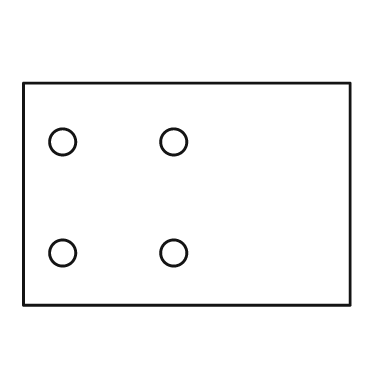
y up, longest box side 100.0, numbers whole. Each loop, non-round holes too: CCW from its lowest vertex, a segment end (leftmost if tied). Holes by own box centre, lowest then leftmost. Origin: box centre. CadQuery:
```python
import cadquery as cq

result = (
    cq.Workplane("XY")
    .moveTo(-50.0, -34.0)
    .lineTo(50.0, -34.0)
    .lineTo(50.0, 34.0)
    .lineTo(-50.0, 34.0)
    .close()
    .moveTo(-38.0, -18.0)
    .circle(4.0)
    .moveTo(-4.0, -18.0)
    .circle(4.0)
    .moveTo(-38.0, 16.0)
    .circle(4.0)
    .moveTo(-4.0, 16.0)
    .circle(4.0)
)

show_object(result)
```